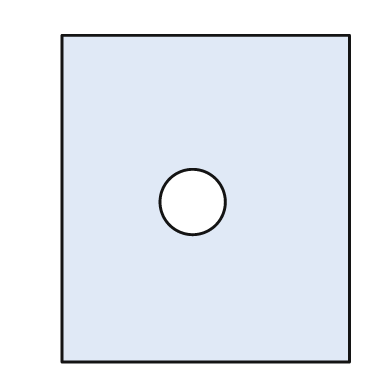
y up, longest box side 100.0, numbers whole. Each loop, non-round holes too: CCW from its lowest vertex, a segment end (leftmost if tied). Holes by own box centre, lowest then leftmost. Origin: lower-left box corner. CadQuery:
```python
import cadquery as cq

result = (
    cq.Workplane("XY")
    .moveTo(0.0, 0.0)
    .lineTo(88.0, 0.0)
    .lineTo(88.0, 100.0)
    .lineTo(0.0, 100.0)
    .close()
    .moveTo(40.0, 49.0)
    .circle(10.0)
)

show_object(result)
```